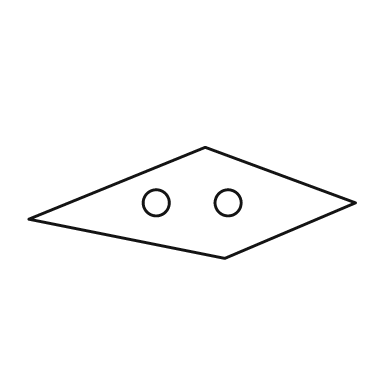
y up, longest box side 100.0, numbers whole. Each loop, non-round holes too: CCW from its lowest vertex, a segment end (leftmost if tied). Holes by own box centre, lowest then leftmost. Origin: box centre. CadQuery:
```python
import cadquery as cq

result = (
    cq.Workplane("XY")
    .moveTo(10.0, -17.0)
    .lineTo(50.0, 0.0)
    .lineTo(4.0, 17.0)
    .lineTo(-50.0, -5.0)
    .close()
    .moveTo(-11.0, 0.0)
    .circle(4.0)
    .moveTo(11.0, 0.0)
    .circle(4.0)
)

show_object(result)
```